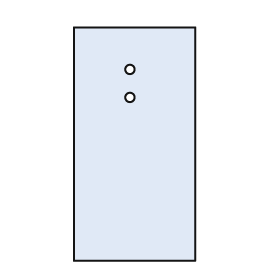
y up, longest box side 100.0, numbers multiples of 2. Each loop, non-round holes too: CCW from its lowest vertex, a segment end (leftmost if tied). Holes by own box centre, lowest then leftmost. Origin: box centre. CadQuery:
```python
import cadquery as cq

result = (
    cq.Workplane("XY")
    .moveTo(-26.0, -50.0)
    .lineTo(26.0, -50.0)
    .lineTo(26.0, 50.0)
    .lineTo(-26.0, 50.0)
    .close()
    .moveTo(-2.0, 20.0)
    .circle(2.0)
    .moveTo(-2.0, 32.0)
    .circle(2.0)
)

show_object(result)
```